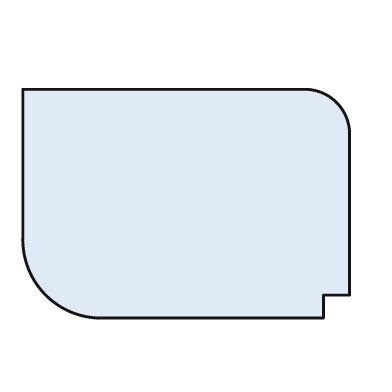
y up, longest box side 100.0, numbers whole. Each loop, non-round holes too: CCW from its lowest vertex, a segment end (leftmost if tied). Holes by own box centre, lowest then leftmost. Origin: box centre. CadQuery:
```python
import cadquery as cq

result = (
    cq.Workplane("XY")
    .moveTo(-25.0, -35.0)
    .lineTo(42.0, -35.0)
    .lineTo(42.0, -28.0)
    .lineTo(50.0, -28.0)
    .lineTo(50.0, 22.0)
    .threePointArc((46.0, 31.0), (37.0, 35.0))
    .lineTo(-50.0, 35.0)
    .lineTo(-50.0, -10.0)
    .threePointArc((-43.0, -28.0), (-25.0, -35.0))
    .close()
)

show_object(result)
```